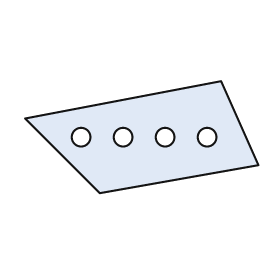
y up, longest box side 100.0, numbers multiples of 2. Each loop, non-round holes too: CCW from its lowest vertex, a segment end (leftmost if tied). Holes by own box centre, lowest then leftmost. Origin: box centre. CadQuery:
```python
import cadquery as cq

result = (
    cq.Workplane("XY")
    .moveTo(-18.0, -24.0)
    .lineTo(50.0, -12.0)
    .lineTo(34.0, 24.0)
    .lineTo(-50.0, 8.0)
    .close()
    .moveTo(-26.0, 0.0)
    .circle(4.0)
    .moveTo(-8.0, 0.0)
    .circle(4.0)
    .moveTo(10.0, 0.0)
    .circle(4.0)
    .moveTo(28.0, 0.0)
    .circle(4.0)
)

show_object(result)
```